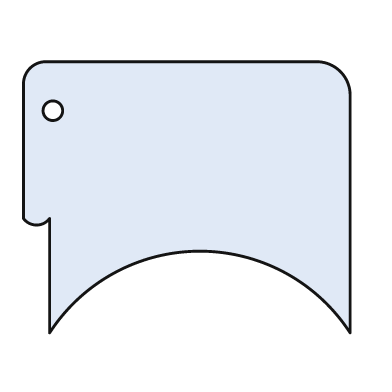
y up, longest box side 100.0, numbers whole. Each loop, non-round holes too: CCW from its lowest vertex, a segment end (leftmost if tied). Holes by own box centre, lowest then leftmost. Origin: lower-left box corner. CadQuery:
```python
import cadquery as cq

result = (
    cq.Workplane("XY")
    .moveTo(8.0, 0.0)
    .threePointArc((54.0, 25.0), (100.0, 0.0))
    .lineTo(100.0, 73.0)
    .threePointArc((97.0, 80.0), (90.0, 83.0))
    .lineTo(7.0, 83.0)
    .threePointArc((2.0, 81.0), (0.0, 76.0))
    .lineTo(0.0, 35.0)
    .threePointArc((4.0, 33.0), (8.0, 35.0))
    .close()
    .moveTo(9.0, 68.0)
    .circle(3.0)
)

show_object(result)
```